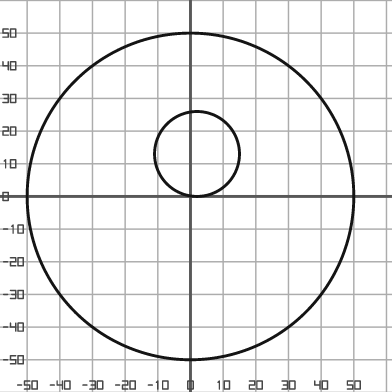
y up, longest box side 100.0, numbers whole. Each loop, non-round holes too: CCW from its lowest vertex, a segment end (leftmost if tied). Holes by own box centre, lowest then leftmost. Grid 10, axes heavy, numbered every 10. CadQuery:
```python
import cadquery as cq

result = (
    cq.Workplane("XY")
    .moveTo(0.0, 0.0)
    .circle(50.0)
    .moveTo(2.0, 13.0)
    .circle(13.0)
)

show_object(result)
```